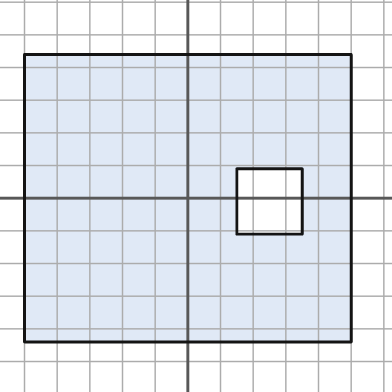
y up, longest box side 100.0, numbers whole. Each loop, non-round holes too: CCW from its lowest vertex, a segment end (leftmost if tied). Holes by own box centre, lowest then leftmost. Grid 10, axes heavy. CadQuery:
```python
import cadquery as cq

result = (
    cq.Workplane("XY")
    .moveTo(-50.0, -44.0)
    .lineTo(50.0, -44.0)
    .lineTo(50.0, 44.0)
    .lineTo(-50.0, 44.0)
    .close()
    .moveTo(15.0, -11.0)
    .lineTo(35.0, -11.0)
    .lineTo(35.0, 9.0)
    .lineTo(15.0, 9.0)
    .close()
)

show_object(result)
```